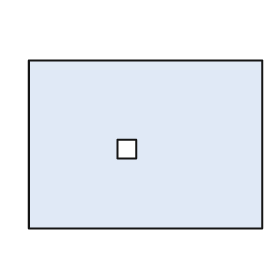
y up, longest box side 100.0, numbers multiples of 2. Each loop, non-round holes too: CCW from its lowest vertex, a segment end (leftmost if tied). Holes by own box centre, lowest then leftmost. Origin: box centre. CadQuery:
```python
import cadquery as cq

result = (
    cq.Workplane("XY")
    .moveTo(-50.0, -36.0)
    .lineTo(50.0, -36.0)
    .lineTo(50.0, 36.0)
    .lineTo(-50.0, 36.0)
    .close()
    .moveTo(-12.0, -6.0)
    .lineTo(-4.0, -6.0)
    .lineTo(-4.0, 2.0)
    .lineTo(-12.0, 2.0)
    .close()
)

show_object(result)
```